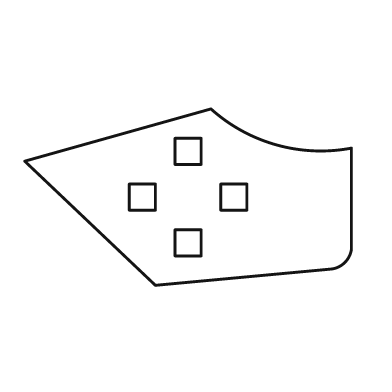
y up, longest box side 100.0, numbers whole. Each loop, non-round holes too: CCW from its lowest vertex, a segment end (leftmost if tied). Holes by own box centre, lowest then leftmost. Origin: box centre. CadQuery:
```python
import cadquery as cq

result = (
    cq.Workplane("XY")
    .moveTo(-10.0, -27.0)
    .lineTo(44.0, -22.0)
    .threePointArc((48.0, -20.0), (50.0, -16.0))
    .lineTo(50.0, 15.0)
    .threePointArc((27.0, 16.0), (7.0, 27.0))
    .lineTo(-50.0, 11.0)
    .close()
    .moveTo(-4.0, -18.0)
    .lineTo(4.0, -18.0)
    .lineTo(4.0, -10.0)
    .lineTo(-4.0, -10.0)
    .close()
    .moveTo(-18.0, -4.0)
    .lineTo(-10.0, -4.0)
    .lineTo(-10.0, 4.0)
    .lineTo(-18.0, 4.0)
    .close()
    .moveTo(10.0, -4.0)
    .lineTo(18.0, -4.0)
    .lineTo(18.0, 4.0)
    .lineTo(10.0, 4.0)
    .close()
    .moveTo(-4.0, 10.0)
    .lineTo(4.0, 10.0)
    .lineTo(4.0, 18.0)
    .lineTo(-4.0, 18.0)
    .close()
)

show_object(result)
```